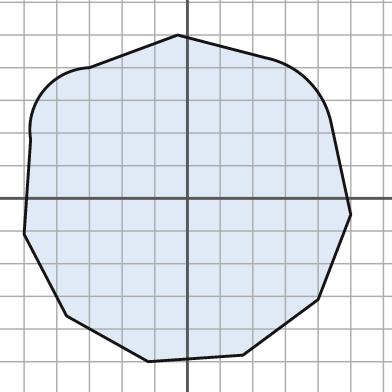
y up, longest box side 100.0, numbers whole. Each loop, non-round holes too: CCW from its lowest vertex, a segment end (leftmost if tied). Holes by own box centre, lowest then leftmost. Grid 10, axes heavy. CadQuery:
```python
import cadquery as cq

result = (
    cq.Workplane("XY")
    .moveTo(-12.0, -50.0)
    .lineTo(17.0, -48.0)
    .lineTo(40.0, -31.0)
    .lineTo(50.0, -5.0)
    .lineTo(44.0, 23.0)
    .threePointArc((37.0, 36.0), (24.0, 43.0))
    .lineTo(-3.0, 50.0)
    .lineTo(-30.0, 40.0)
    .threePointArc((-44.0, 33.0), (-48.0, 18.0))
    .lineTo(-50.0, -11.0)
    .lineTo(-37.0, -36.0)
    .close()
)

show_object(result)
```